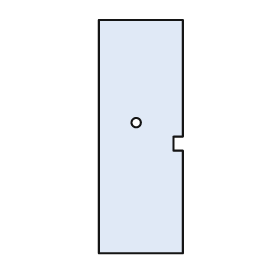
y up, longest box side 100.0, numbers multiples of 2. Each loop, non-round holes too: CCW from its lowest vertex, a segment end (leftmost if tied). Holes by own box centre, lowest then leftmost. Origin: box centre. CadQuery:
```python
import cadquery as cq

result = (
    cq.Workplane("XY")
    .moveTo(-18.0, -50.0)
    .lineTo(18.0, -50.0)
    .lineTo(18.0, -6.0)
    .lineTo(14.0, -6.0)
    .lineTo(14.0, 0.0)
    .lineTo(18.0, 0.0)
    .lineTo(18.0, 50.0)
    .lineTo(-18.0, 50.0)
    .close()
    .moveTo(-2.0, 6.0)
    .circle(2.0)
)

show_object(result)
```